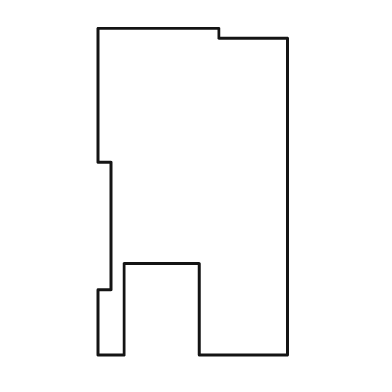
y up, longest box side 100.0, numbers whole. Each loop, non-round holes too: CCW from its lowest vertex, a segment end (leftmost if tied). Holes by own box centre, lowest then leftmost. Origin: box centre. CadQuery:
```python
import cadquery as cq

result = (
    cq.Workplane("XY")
    .moveTo(-29.0, -50.0)
    .lineTo(-21.0, -50.0)
    .lineTo(-21.0, -22.0)
    .lineTo(2.0, -22.0)
    .lineTo(2.0, -50.0)
    .lineTo(29.0, -50.0)
    .lineTo(29.0, 47.0)
    .lineTo(8.0, 47.0)
    .lineTo(8.0, 50.0)
    .lineTo(-29.0, 50.0)
    .lineTo(-29.0, 9.0)
    .lineTo(-25.0, 9.0)
    .lineTo(-25.0, -30.0)
    .lineTo(-29.0, -30.0)
    .close()
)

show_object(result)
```